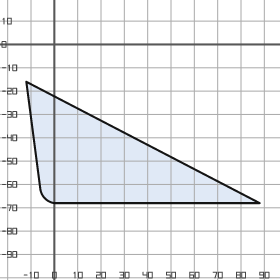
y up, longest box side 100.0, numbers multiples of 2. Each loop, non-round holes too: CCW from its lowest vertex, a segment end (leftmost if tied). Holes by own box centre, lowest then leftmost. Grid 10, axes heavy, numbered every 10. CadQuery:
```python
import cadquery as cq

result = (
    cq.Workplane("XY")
    .moveTo(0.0, -68.0)
    .lineTo(88.0, -68.0)
    .lineTo(-12.0, -16.0)
    .lineTo(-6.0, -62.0)
    .threePointArc((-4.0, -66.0), (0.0, -68.0))
    .close()
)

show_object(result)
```